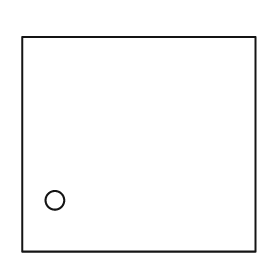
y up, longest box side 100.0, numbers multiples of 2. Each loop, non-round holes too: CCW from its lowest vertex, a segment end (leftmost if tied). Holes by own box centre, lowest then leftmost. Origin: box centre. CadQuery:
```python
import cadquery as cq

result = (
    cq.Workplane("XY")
    .moveTo(-50.0, -46.0)
    .lineTo(50.0, -46.0)
    .lineTo(50.0, 46.0)
    .lineTo(-50.0, 46.0)
    .close()
    .moveTo(-36.0, -24.0)
    .circle(4.0)
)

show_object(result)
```